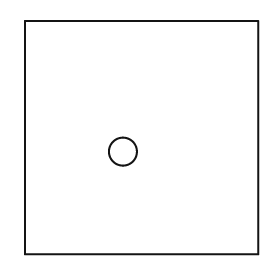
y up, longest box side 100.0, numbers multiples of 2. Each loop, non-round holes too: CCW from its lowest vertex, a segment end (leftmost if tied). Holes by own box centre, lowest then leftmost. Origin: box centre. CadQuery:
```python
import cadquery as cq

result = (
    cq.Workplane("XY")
    .moveTo(-50.0, -50.0)
    .lineTo(50.0, -50.0)
    .lineTo(50.0, 50.0)
    .lineTo(-50.0, 50.0)
    .close()
    .moveTo(-8.0, -6.0)
    .circle(6.0)
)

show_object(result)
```